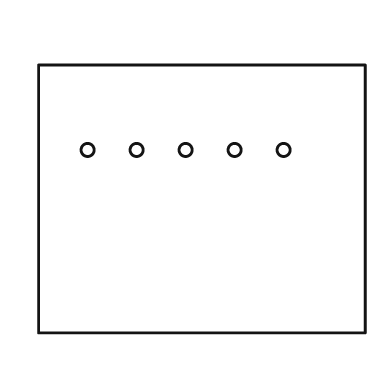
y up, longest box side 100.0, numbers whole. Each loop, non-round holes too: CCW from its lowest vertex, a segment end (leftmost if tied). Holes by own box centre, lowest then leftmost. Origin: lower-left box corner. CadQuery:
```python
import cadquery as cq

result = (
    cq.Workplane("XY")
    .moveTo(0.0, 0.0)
    .lineTo(100.0, 0.0)
    .lineTo(100.0, 82.0)
    .lineTo(0.0, 82.0)
    .close()
    .moveTo(15.0, 56.0)
    .circle(2.0)
    .moveTo(30.0, 56.0)
    .circle(2.0)
    .moveTo(45.0, 56.0)
    .circle(2.0)
    .moveTo(60.0, 56.0)
    .circle(2.0)
    .moveTo(75.0, 56.0)
    .circle(2.0)
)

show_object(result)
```